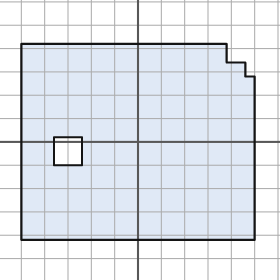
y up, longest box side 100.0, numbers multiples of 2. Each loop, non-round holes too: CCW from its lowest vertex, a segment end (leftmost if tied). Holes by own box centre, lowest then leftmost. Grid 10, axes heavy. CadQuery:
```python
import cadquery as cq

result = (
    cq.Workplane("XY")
    .moveTo(-50.0, -42.0)
    .lineTo(50.0, -42.0)
    .lineTo(50.0, 28.0)
    .lineTo(46.0, 28.0)
    .lineTo(46.0, 34.0)
    .lineTo(38.0, 34.0)
    .lineTo(38.0, 42.0)
    .lineTo(-50.0, 42.0)
    .close()
    .moveTo(-36.0, -10.0)
    .lineTo(-24.0, -10.0)
    .lineTo(-24.0, 2.0)
    .lineTo(-36.0, 2.0)
    .close()
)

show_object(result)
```